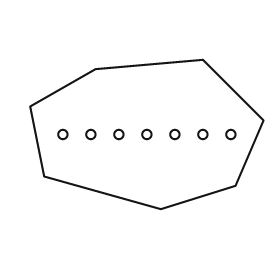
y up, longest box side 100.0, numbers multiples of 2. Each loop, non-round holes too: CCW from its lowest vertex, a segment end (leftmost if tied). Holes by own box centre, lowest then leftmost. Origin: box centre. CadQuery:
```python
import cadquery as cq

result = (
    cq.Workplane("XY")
    .moveTo(6.0, -32.0)
    .lineTo(38.0, -22.0)
    .lineTo(50.0, 6.0)
    .lineTo(24.0, 32.0)
    .lineTo(-22.0, 28.0)
    .lineTo(-50.0, 12.0)
    .lineTo(-44.0, -18.0)
    .close()
    .moveTo(-36.0, 0.0)
    .circle(2.0)
    .moveTo(-24.0, 0.0)
    .circle(2.0)
    .moveTo(-12.0, 0.0)
    .circle(2.0)
    .moveTo(0.0, 0.0)
    .circle(2.0)
    .moveTo(12.0, 0.0)
    .circle(2.0)
    .moveTo(24.0, 0.0)
    .circle(2.0)
    .moveTo(36.0, 0.0)
    .circle(2.0)
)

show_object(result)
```